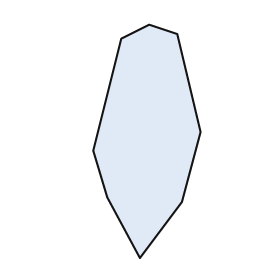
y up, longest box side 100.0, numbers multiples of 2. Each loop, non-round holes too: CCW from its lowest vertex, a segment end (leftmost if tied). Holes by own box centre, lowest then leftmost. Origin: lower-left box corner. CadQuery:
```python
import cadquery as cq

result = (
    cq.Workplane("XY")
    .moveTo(20.0, 0.0)
    .lineTo(38.0, 24.0)
    .lineTo(46.0, 54.0)
    .lineTo(36.0, 96.0)
    .lineTo(24.0, 100.0)
    .lineTo(12.0, 94.0)
    .lineTo(0.0, 46.0)
    .lineTo(6.0, 26.0)
    .close()
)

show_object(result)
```